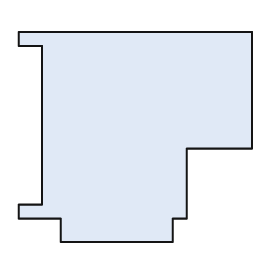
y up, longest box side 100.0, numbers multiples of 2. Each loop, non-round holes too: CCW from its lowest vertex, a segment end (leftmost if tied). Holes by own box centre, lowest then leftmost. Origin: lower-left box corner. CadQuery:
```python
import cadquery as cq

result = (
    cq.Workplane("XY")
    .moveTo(18.0, 0.0)
    .lineTo(66.0, 0.0)
    .lineTo(66.0, 10.0)
    .lineTo(72.0, 10.0)
    .lineTo(72.0, 40.0)
    .lineTo(100.0, 40.0)
    .lineTo(100.0, 90.0)
    .lineTo(0.0, 90.0)
    .lineTo(0.0, 84.0)
    .lineTo(10.0, 84.0)
    .lineTo(10.0, 16.0)
    .lineTo(0.0, 16.0)
    .lineTo(0.0, 10.0)
    .lineTo(18.0, 10.0)
    .close()
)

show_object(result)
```